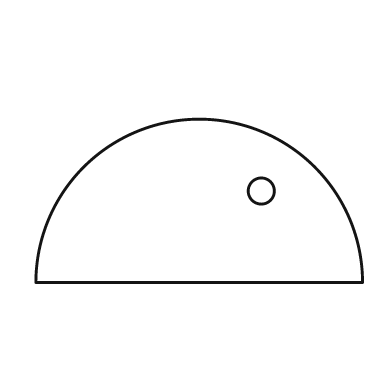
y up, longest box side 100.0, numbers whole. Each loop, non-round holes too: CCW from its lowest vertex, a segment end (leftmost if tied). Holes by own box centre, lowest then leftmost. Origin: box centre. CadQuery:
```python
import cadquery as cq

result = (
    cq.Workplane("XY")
    .moveTo(-50.0, -25.0)
    .lineTo(50.0, -25.0)
    .threePointArc((0.0, 25.0), (-50.0, -25.0))
    .close()
    .moveTo(19.0, 3.0)
    .circle(4.0)
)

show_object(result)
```